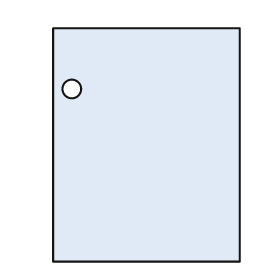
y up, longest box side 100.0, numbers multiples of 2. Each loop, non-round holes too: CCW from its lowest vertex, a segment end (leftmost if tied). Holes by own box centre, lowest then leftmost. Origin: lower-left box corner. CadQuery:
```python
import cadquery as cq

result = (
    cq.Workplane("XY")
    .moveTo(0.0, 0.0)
    .lineTo(80.0, 0.0)
    .lineTo(80.0, 100.0)
    .lineTo(0.0, 100.0)
    .close()
    .moveTo(8.0, 74.0)
    .circle(4.0)
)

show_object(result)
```